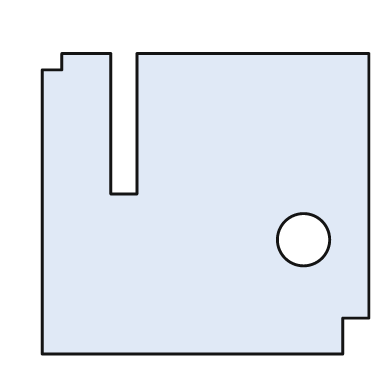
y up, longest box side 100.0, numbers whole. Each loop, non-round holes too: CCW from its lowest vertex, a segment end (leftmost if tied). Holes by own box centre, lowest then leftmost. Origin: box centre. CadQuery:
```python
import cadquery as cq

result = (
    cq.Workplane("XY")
    .moveTo(-50.0, -46.0)
    .lineTo(42.0, -46.0)
    .lineTo(42.0, -35.0)
    .lineTo(50.0, -35.0)
    .lineTo(50.0, 46.0)
    .lineTo(-21.0, 46.0)
    .lineTo(-21.0, 3.0)
    .lineTo(-29.0, 3.0)
    .lineTo(-29.0, 46.0)
    .lineTo(-44.0, 46.0)
    .lineTo(-44.0, 41.0)
    .lineTo(-50.0, 41.0)
    .close()
    .moveTo(30.0, -11.0)
    .circle(8.0)
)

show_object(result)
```